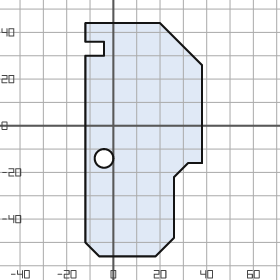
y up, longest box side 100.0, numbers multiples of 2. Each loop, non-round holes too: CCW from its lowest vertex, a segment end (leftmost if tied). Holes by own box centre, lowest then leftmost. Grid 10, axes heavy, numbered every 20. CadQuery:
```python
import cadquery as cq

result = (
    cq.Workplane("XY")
    .moveTo(-6.0, -56.0)
    .lineTo(18.0, -56.0)
    .lineTo(26.0, -48.0)
    .lineTo(26.0, -22.0)
    .lineTo(32.0, -16.0)
    .lineTo(38.0, -16.0)
    .lineTo(38.0, 26.0)
    .lineTo(20.0, 44.0)
    .lineTo(-12.0, 44.0)
    .lineTo(-12.0, 36.0)
    .lineTo(-4.0, 36.0)
    .lineTo(-4.0, 30.0)
    .lineTo(-12.0, 30.0)
    .lineTo(-12.0, -50.0)
    .close()
    .moveTo(-4.0, -14.0)
    .circle(4.0)
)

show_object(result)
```